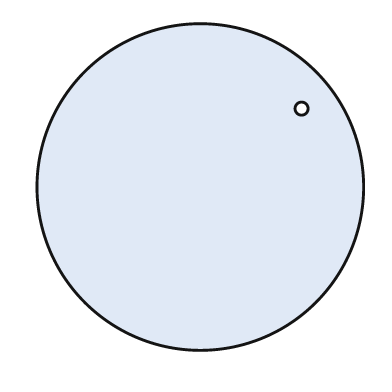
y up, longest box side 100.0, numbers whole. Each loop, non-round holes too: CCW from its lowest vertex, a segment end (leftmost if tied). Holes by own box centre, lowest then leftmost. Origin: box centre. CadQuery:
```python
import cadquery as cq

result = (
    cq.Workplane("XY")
    .moveTo(0.0, 0.0)
    .circle(50.0)
    .moveTo(31.0, 24.0)
    .circle(2.0)
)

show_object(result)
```